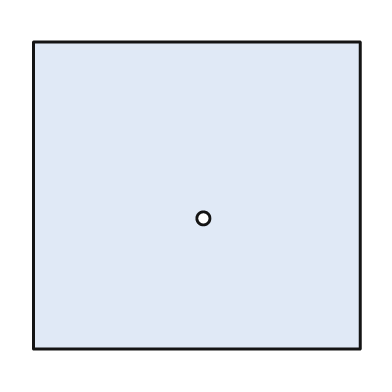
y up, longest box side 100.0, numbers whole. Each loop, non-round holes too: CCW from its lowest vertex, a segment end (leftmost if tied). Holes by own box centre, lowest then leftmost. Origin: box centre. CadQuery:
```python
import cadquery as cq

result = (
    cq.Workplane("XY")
    .moveTo(-50.0, -47.0)
    .lineTo(50.0, -47.0)
    .lineTo(50.0, 47.0)
    .lineTo(-50.0, 47.0)
    .close()
    .moveTo(2.0, -7.0)
    .circle(2.0)
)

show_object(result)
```